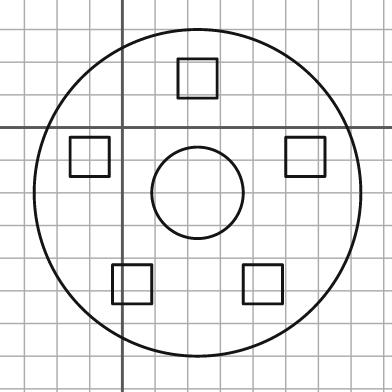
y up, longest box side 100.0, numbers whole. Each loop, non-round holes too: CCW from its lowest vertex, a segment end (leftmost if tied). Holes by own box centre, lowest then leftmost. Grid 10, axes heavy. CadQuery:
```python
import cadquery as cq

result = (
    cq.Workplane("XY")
    .moveTo(23.0, -20.0)
    .circle(50.0)
    .moveTo(-3.0, -54.0)
    .lineTo(9.0, -54.0)
    .lineTo(9.0, -42.0)
    .lineTo(-3.0, -42.0)
    .close()
    .moveTo(37.0, -54.0)
    .lineTo(49.0, -54.0)
    .lineTo(49.0, -42.0)
    .lineTo(37.0, -42.0)
    .close()
    .moveTo(23.0, -20.0)
    .circle(14.0)
    .moveTo(-16.0, -15.0)
    .lineTo(-4.0, -15.0)
    .lineTo(-4.0, -3.0)
    .lineTo(-16.0, -3.0)
    .close()
    .moveTo(50.0, -15.0)
    .lineTo(62.0, -15.0)
    .lineTo(62.0, -3.0)
    .lineTo(50.0, -3.0)
    .close()
    .moveTo(17.0, 9.0)
    .lineTo(29.0, 9.0)
    .lineTo(29.0, 21.0)
    .lineTo(17.0, 21.0)
    .close()
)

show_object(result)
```